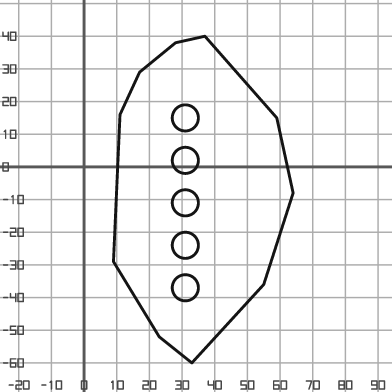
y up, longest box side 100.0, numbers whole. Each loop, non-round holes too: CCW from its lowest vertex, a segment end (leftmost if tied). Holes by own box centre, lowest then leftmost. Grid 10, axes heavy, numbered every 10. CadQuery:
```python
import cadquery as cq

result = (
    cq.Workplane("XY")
    .moveTo(33.0, -60.0)
    .lineTo(55.0, -36.0)
    .lineTo(64.0, -8.0)
    .lineTo(59.0, 15.0)
    .lineTo(37.0, 40.0)
    .lineTo(28.0, 38.0)
    .lineTo(17.0, 29.0)
    .lineTo(11.0, 16.0)
    .lineTo(9.0, -29.0)
    .lineTo(23.0, -52.0)
    .close()
    .moveTo(31.0, -37.0)
    .circle(4.0)
    .moveTo(31.0, -24.0)
    .circle(4.0)
    .moveTo(31.0, -11.0)
    .circle(4.0)
    .moveTo(31.0, 2.0)
    .circle(4.0)
    .moveTo(31.0, 15.0)
    .circle(4.0)
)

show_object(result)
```